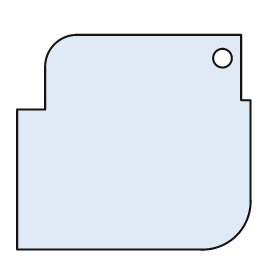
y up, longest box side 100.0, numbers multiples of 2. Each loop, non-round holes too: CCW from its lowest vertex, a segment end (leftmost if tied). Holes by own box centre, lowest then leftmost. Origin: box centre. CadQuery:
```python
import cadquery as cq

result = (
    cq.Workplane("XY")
    .moveTo(-50.0, -46.0)
    .lineTo(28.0, -46.0)
    .threePointArc((44.0, -40.0), (50.0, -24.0))
    .lineTo(50.0, 18.0)
    .lineTo(46.0, 18.0)
    .lineTo(46.0, 46.0)
    .lineTo(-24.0, 46.0)
    .threePointArc((-34.0, 42.0), (-38.0, 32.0))
    .lineTo(-38.0, 14.0)
    .lineTo(-50.0, 14.0)
    .close()
    .moveTo(38.0, 36.0)
    .circle(4.0)
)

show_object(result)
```